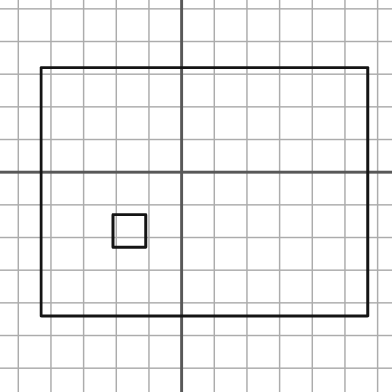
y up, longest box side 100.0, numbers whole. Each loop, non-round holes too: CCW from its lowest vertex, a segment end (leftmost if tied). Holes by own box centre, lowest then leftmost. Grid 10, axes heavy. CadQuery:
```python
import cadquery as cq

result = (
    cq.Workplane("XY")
    .moveTo(-43.0, -44.0)
    .lineTo(57.0, -44.0)
    .lineTo(57.0, 32.0)
    .lineTo(-43.0, 32.0)
    .close()
    .moveTo(-21.0, -23.0)
    .lineTo(-11.0, -23.0)
    .lineTo(-11.0, -13.0)
    .lineTo(-21.0, -13.0)
    .close()
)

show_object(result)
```